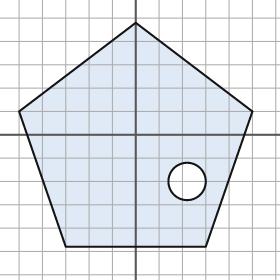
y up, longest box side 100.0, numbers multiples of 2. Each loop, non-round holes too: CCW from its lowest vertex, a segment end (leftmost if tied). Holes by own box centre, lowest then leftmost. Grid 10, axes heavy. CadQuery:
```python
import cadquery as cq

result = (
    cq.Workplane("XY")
    .moveTo(-30.0, -48.0)
    .lineTo(30.0, -48.0)
    .lineTo(50.0, 10.0)
    .lineTo(0.0, 48.0)
    .lineTo(-50.0, 10.0)
    .close()
    .moveTo(22.0, -20.0)
    .circle(8.0)
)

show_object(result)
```